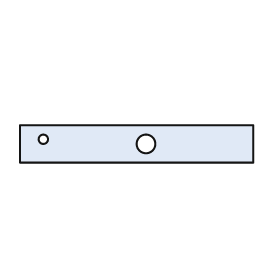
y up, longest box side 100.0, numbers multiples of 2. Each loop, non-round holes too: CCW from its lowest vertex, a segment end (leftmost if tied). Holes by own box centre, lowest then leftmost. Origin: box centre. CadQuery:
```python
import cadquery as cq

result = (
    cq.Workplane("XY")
    .moveTo(-50.0, -8.0)
    .lineTo(50.0, -8.0)
    .lineTo(50.0, 8.0)
    .lineTo(-50.0, 8.0)
    .close()
    .moveTo(4.0, 0.0)
    .circle(4.0)
    .moveTo(-40.0, 2.0)
    .circle(2.0)
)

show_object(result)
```